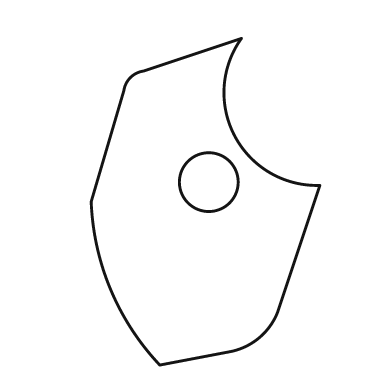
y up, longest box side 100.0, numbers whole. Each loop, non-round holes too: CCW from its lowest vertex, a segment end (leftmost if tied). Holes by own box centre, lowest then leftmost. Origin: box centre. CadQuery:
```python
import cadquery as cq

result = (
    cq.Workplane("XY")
    .moveTo(-14.0, -50.0)
    .lineTo(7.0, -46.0)
    .threePointArc((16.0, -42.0), (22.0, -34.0))
    .lineTo(35.0, 5.0)
    .threePointArc((9.0, 20.0), (11.0, 50.0))
    .lineTo(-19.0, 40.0)
    .threePointArc((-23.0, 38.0), (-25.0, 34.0))
    .lineTo(-35.0, 0.0)
    .threePointArc((-29.0, -27.0), (-14.0, -50.0))
    .close()
    .moveTo(1.0, 6.0)
    .circle(9.0)
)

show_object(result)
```